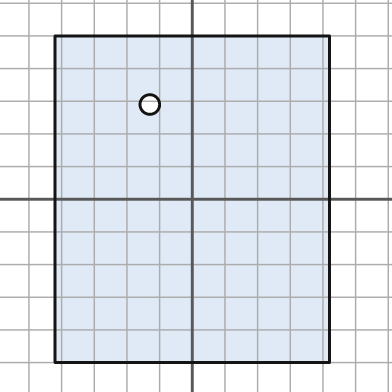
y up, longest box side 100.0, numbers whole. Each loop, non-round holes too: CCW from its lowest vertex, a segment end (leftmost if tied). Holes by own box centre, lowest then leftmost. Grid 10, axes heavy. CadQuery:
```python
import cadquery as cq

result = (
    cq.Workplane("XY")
    .moveTo(-42.0, -50.0)
    .lineTo(42.0, -50.0)
    .lineTo(42.0, 50.0)
    .lineTo(-42.0, 50.0)
    .close()
    .moveTo(-13.0, 29.0)
    .circle(3.0)
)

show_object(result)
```